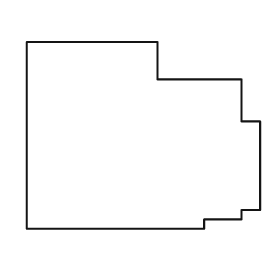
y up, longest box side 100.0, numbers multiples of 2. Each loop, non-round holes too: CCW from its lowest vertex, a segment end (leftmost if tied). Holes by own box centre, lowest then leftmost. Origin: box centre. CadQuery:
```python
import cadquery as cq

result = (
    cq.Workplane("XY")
    .moveTo(-50.0, -40.0)
    .lineTo(26.0, -40.0)
    .lineTo(26.0, -36.0)
    .lineTo(42.0, -36.0)
    .lineTo(42.0, -32.0)
    .lineTo(50.0, -32.0)
    .lineTo(50.0, 6.0)
    .lineTo(42.0, 6.0)
    .lineTo(42.0, 24.0)
    .lineTo(6.0, 24.0)
    .lineTo(6.0, 40.0)
    .lineTo(-50.0, 40.0)
    .close()
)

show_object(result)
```